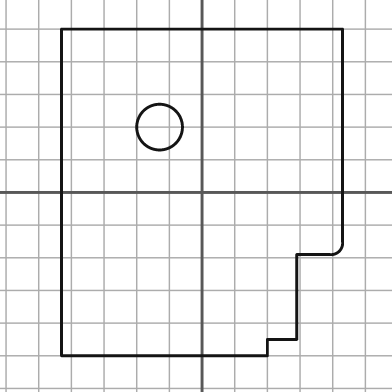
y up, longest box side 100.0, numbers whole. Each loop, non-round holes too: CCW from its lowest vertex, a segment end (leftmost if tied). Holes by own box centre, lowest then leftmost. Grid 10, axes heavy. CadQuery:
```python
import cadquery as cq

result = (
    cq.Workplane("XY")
    .moveTo(-43.0, -50.0)
    .lineTo(20.0, -50.0)
    .lineTo(20.0, -45.0)
    .lineTo(29.0, -45.0)
    .lineTo(29.0, -19.0)
    .lineTo(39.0, -19.0)
    .threePointArc((42.0, -18.0), (43.0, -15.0))
    .lineTo(43.0, 50.0)
    .lineTo(-43.0, 50.0)
    .close()
    .moveTo(-13.0, 20.0)
    .circle(7.0)
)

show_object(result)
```